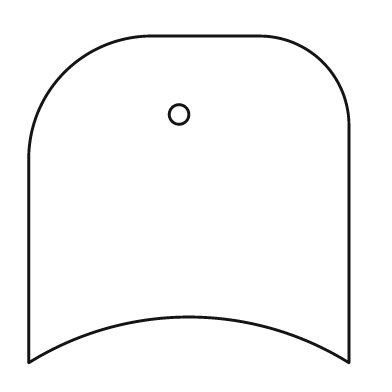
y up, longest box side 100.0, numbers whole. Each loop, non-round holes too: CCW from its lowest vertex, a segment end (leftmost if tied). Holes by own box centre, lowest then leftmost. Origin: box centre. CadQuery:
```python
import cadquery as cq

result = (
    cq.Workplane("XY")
    .moveTo(-49.0, -50.0)
    .threePointArc((0.0, -36.0), (49.0, -50.0))
    .lineTo(49.0, 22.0)
    .threePointArc((41.0, 42.0), (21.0, 50.0))
    .lineTo(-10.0, 50.0)
    .threePointArc((-38.0, 39.0), (-49.0, 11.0))
    .close()
    .moveTo(-3.0, 26.0)
    .circle(3.0)
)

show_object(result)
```